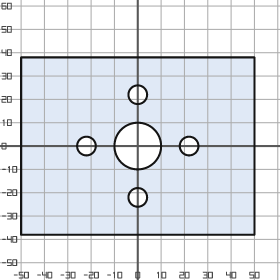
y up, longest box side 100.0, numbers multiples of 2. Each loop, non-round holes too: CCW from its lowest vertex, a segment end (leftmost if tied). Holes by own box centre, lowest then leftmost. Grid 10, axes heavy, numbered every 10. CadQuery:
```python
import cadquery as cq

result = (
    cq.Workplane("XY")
    .moveTo(-50.0, -38.0)
    .lineTo(50.0, -38.0)
    .lineTo(50.0, 38.0)
    .lineTo(-50.0, 38.0)
    .close()
    .moveTo(0.0, -22.0)
    .circle(4.0)
    .moveTo(-22.0, 0.0)
    .circle(4.0)
    .moveTo(0.0, 0.0)
    .circle(10.0)
    .moveTo(22.0, 0.0)
    .circle(4.0)
    .moveTo(0.0, 22.0)
    .circle(4.0)
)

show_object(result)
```